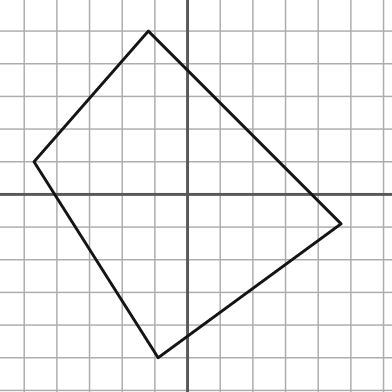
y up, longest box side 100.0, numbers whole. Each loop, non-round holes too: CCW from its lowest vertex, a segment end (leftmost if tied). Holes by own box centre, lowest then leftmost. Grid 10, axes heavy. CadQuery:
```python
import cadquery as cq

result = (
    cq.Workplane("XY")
    .moveTo(-9.0, -50.0)
    .lineTo(47.0, -9.0)
    .lineTo(-12.0, 50.0)
    .lineTo(-47.0, 10.0)
    .close()
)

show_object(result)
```